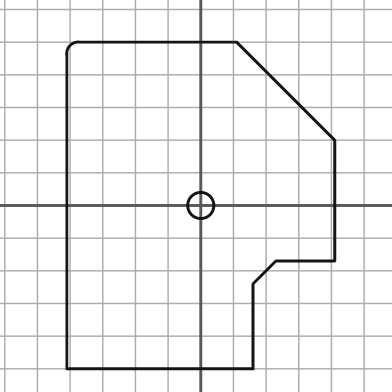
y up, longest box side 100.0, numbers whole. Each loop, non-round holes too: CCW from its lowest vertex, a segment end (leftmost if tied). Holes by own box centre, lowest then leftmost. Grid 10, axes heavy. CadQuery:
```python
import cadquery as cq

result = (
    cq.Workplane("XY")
    .moveTo(-41.0, -50.0)
    .lineTo(16.0, -50.0)
    .lineTo(16.0, -24.0)
    .lineTo(23.0, -17.0)
    .lineTo(41.0, -17.0)
    .lineTo(41.0, 20.0)
    .lineTo(11.0, 50.0)
    .lineTo(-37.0, 50.0)
    .threePointArc((-40.0, 49.0), (-41.0, 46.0))
    .close()
    .moveTo(0.0, 0.0)
    .circle(4.0)
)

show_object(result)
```